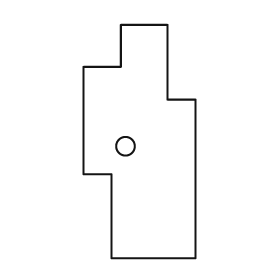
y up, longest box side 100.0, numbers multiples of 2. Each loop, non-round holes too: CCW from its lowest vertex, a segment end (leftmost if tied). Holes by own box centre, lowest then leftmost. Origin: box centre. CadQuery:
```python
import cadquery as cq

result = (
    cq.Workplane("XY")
    .moveTo(-12.0, -50.0)
    .lineTo(24.0, -50.0)
    .lineTo(24.0, 18.0)
    .lineTo(12.0, 18.0)
    .lineTo(12.0, 50.0)
    .lineTo(-8.0, 50.0)
    .lineTo(-8.0, 32.0)
    .lineTo(-24.0, 32.0)
    .lineTo(-24.0, -14.0)
    .lineTo(-12.0, -14.0)
    .close()
    .moveTo(-6.0, -2.0)
    .circle(4.0)
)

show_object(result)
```